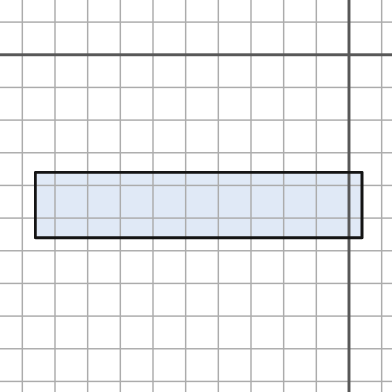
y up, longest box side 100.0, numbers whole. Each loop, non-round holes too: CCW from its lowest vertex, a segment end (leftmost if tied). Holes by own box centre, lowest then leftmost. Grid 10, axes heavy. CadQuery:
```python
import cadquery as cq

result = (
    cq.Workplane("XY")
    .moveTo(-96.0, -56.0)
    .lineTo(4.0, -56.0)
    .lineTo(4.0, -36.0)
    .lineTo(-96.0, -36.0)
    .close()
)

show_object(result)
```